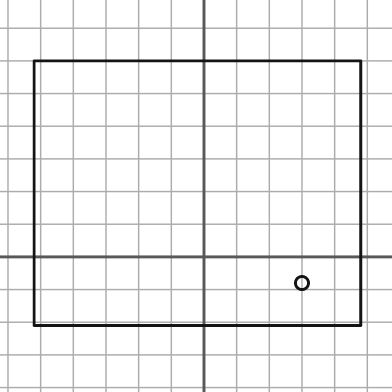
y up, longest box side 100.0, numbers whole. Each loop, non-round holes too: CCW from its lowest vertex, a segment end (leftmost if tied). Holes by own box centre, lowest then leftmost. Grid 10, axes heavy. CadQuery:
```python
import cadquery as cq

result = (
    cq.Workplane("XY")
    .moveTo(-52.0, -21.0)
    .lineTo(48.0, -21.0)
    .lineTo(48.0, 60.0)
    .lineTo(-52.0, 60.0)
    .close()
    .moveTo(30.0, -8.0)
    .circle(2.0)
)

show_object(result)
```